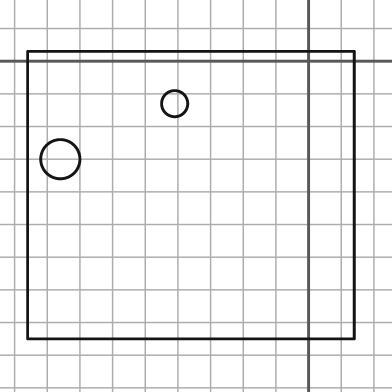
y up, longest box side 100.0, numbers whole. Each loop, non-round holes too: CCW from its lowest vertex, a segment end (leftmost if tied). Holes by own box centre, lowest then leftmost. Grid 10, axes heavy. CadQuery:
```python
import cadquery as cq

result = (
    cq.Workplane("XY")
    .moveTo(-86.0, -85.0)
    .lineTo(14.0, -85.0)
    .lineTo(14.0, 3.0)
    .lineTo(-86.0, 3.0)
    .close()
    .moveTo(-76.0, -30.0)
    .circle(6.0)
    .moveTo(-41.0, -13.0)
    .circle(4.0)
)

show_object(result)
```